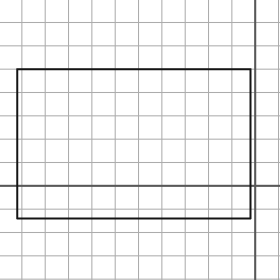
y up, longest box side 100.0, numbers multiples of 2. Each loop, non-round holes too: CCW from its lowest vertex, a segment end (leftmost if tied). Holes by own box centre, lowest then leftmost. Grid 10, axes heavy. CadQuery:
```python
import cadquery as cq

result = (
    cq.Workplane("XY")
    .moveTo(-102.0, -14.0)
    .lineTo(-2.0, -14.0)
    .lineTo(-2.0, 50.0)
    .lineTo(-102.0, 50.0)
    .close()
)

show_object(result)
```